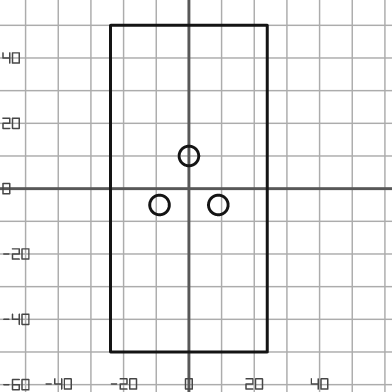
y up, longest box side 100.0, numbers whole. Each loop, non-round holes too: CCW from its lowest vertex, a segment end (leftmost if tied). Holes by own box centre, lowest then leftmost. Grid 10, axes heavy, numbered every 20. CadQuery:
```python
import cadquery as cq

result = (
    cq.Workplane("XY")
    .moveTo(-24.0, -50.0)
    .lineTo(24.0, -50.0)
    .lineTo(24.0, 50.0)
    .lineTo(-24.0, 50.0)
    .close()
    .moveTo(-9.0, -5.0)
    .circle(3.0)
    .moveTo(9.0, -5.0)
    .circle(3.0)
    .moveTo(0.0, 10.0)
    .circle(3.0)
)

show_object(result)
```